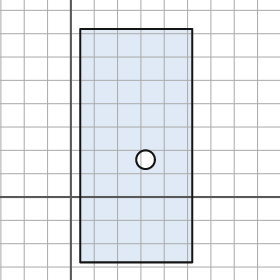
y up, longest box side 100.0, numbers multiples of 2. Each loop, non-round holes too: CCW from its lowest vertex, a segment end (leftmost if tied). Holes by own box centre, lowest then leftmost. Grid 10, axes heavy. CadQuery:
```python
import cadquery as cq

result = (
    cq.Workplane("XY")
    .moveTo(4.0, -28.0)
    .lineTo(52.0, -28.0)
    .lineTo(52.0, 72.0)
    .lineTo(4.0, 72.0)
    .close()
    .moveTo(32.0, 16.0)
    .circle(4.0)
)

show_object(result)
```